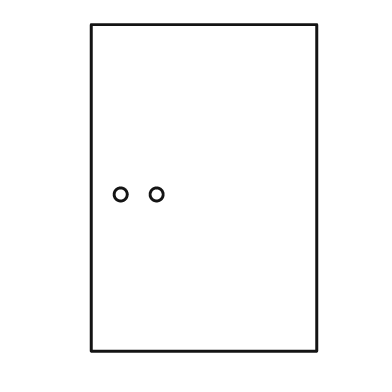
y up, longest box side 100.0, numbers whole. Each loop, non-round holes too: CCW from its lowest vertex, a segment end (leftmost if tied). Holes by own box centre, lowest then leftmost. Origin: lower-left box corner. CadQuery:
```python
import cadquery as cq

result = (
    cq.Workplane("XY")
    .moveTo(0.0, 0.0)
    .lineTo(69.0, 0.0)
    .lineTo(69.0, 100.0)
    .lineTo(0.0, 100.0)
    .close()
    .moveTo(9.0, 48.0)
    .circle(2.0)
    .moveTo(20.0, 48.0)
    .circle(2.0)
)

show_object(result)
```